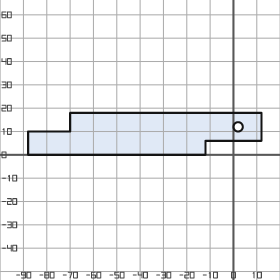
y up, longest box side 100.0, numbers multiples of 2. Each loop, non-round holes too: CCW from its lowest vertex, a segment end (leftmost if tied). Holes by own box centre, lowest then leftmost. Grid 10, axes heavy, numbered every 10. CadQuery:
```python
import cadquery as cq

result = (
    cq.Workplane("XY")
    .moveTo(-88.0, 0.0)
    .lineTo(-12.0, 0.0)
    .lineTo(-12.0, 6.0)
    .lineTo(12.0, 6.0)
    .lineTo(12.0, 18.0)
    .lineTo(-70.0, 18.0)
    .lineTo(-70.0, 10.0)
    .lineTo(-88.0, 10.0)
    .close()
    .moveTo(2.0, 12.0)
    .circle(2.0)
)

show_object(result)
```